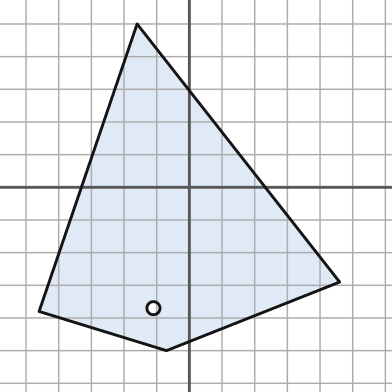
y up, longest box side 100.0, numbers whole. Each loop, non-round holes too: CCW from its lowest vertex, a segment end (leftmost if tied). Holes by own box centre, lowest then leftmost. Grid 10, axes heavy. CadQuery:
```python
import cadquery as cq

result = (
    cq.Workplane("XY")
    .moveTo(-7.0, -50.0)
    .lineTo(46.0, -29.0)
    .lineTo(-16.0, 50.0)
    .lineTo(-46.0, -38.0)
    .close()
    .moveTo(-11.0, -37.0)
    .circle(2.0)
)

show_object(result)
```